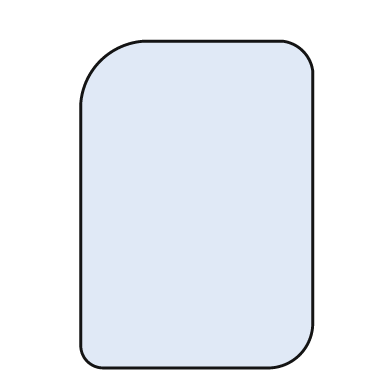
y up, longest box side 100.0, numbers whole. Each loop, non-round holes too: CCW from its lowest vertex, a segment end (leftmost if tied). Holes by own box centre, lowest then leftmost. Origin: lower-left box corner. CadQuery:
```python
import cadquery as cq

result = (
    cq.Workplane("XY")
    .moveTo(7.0, 0.0)
    .lineTo(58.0, 0.0)
    .threePointArc((67.0, 4.0), (71.0, 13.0))
    .lineTo(71.0, 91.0)
    .threePointArc((68.0, 97.0), (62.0, 100.0))
    .lineTo(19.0, 100.0)
    .threePointArc((6.0, 94.0), (0.0, 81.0))
    .lineTo(0.0, 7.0)
    .threePointArc((2.0, 2.0), (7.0, 0.0))
    .close()
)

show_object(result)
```